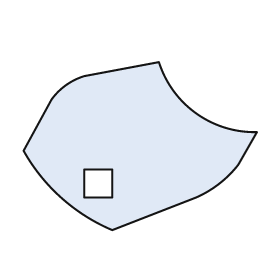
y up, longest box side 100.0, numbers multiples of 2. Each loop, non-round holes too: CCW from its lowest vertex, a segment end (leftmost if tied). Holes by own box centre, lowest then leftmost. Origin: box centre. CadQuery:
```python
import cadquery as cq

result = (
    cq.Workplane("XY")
    .moveTo(-12.0, -36.0)
    .lineTo(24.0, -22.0)
    .threePointArc((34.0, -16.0), (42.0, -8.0))
    .lineTo(50.0, 6.0)
    .threePointArc((24.0, 14.0), (8.0, 36.0))
    .lineTo(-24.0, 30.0)
    .threePointArc((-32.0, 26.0), (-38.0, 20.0))
    .lineTo(-50.0, -2.0)
    .threePointArc((-34.0, -22.0), (-12.0, -36.0))
    .close()
    .moveTo(-24.0, -22.0)
    .lineTo(-12.0, -22.0)
    .lineTo(-12.0, -10.0)
    .lineTo(-24.0, -10.0)
    .close()
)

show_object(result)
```